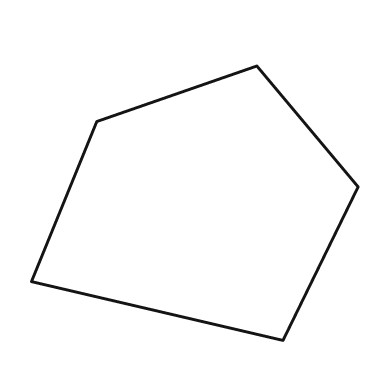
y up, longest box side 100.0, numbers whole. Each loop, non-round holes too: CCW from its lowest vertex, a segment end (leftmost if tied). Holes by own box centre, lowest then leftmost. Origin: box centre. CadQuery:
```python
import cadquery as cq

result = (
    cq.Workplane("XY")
    .moveTo(27.0, -42.0)
    .lineTo(50.0, 5.0)
    .lineTo(19.0, 42.0)
    .lineTo(-30.0, 25.0)
    .lineTo(-50.0, -24.0)
    .close()
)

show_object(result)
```